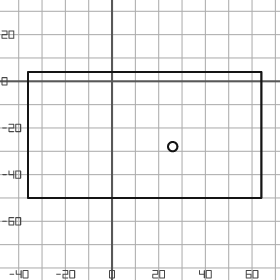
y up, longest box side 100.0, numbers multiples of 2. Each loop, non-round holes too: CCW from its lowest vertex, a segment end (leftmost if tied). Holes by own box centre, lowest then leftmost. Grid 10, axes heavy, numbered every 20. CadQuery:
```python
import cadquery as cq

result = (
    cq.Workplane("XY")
    .moveTo(-36.0, -50.0)
    .lineTo(64.0, -50.0)
    .lineTo(64.0, 4.0)
    .lineTo(-36.0, 4.0)
    .close()
    .moveTo(26.0, -28.0)
    .circle(2.0)
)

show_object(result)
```